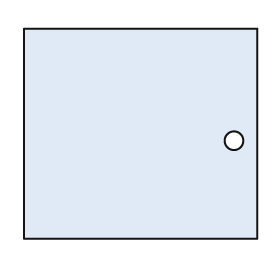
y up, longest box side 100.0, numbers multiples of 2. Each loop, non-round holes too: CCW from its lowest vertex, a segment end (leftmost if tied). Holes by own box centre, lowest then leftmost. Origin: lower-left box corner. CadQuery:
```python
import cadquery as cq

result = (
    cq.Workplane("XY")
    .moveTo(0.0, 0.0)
    .lineTo(100.0, 0.0)
    .lineTo(100.0, 90.0)
    .lineTo(0.0, 90.0)
    .close()
    .moveTo(90.0, 42.0)
    .circle(4.0)
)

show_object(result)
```